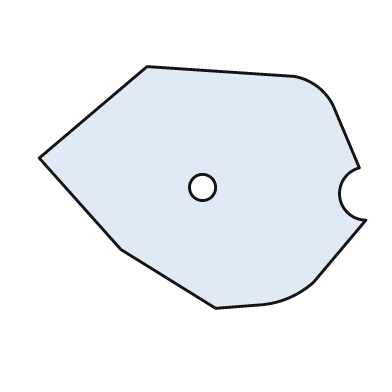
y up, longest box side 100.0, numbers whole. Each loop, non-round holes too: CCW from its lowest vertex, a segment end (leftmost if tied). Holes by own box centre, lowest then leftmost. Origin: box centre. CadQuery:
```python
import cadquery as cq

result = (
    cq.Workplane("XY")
    .moveTo(4.0, -37.0)
    .lineTo(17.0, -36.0)
    .threePointArc((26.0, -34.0), (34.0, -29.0))
    .lineTo(50.0, -10.0)
    .threePointArc((42.0, -3.0), (48.0, 6.0))
    .lineTo(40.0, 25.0)
    .threePointArc((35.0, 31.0), (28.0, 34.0))
    .lineTo(-17.0, 37.0)
    .lineTo(-50.0, 9.0)
    .lineTo(-25.0, -19.0)
    .close()
    .moveTo(0.0, 0.0)
    .circle(4.0)
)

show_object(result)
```